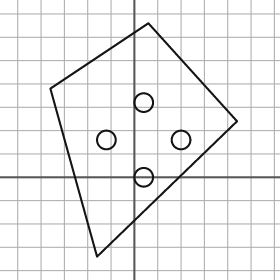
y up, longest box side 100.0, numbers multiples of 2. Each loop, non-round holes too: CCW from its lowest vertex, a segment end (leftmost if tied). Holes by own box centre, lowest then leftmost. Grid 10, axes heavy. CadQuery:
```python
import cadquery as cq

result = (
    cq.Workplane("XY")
    .moveTo(-16.0, -34.0)
    .lineTo(44.0, 24.0)
    .lineTo(6.0, 66.0)
    .lineTo(-36.0, 38.0)
    .close()
    .moveTo(4.0, 0.0)
    .circle(4.0)
    .moveTo(-12.0, 16.0)
    .circle(4.0)
    .moveTo(20.0, 16.0)
    .circle(4.0)
    .moveTo(4.0, 32.0)
    .circle(4.0)
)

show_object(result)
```